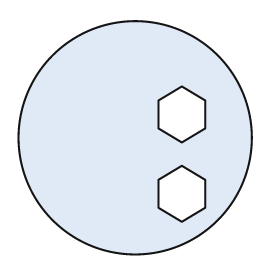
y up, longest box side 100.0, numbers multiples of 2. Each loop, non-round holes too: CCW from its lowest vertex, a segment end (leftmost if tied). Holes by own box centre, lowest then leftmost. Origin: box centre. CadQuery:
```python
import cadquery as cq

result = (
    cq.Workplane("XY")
    .moveTo(0.0, 0.0)
    .circle(50.0)
    .moveTo(20.0, -36.0)
    .lineTo(30.0, -30.0)
    .lineTo(30.0, -18.0)
    .lineTo(20.0, -12.0)
    .lineTo(10.0, -18.0)
    .lineTo(10.0, -30.0)
    .close()
    .moveTo(20.0, -2.0)
    .lineTo(30.0, 4.0)
    .lineTo(30.0, 16.0)
    .lineTo(20.0, 22.0)
    .lineTo(10.0, 16.0)
    .lineTo(10.0, 4.0)
    .close()
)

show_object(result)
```